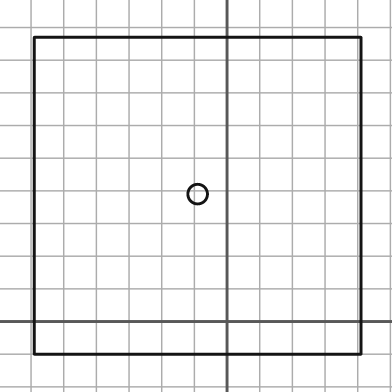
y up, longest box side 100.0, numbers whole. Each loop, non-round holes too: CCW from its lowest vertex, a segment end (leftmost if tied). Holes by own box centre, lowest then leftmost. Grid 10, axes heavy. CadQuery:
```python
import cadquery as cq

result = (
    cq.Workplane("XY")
    .moveTo(-59.0, -10.0)
    .lineTo(41.0, -10.0)
    .lineTo(41.0, 87.0)
    .lineTo(-59.0, 87.0)
    .close()
    .moveTo(-9.0, 39.0)
    .circle(3.0)
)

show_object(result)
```